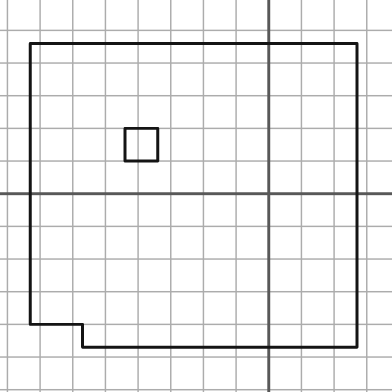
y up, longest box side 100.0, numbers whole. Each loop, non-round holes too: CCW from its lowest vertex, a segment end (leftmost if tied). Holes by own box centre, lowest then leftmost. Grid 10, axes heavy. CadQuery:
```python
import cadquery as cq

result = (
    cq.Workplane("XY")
    .moveTo(-57.0, -47.0)
    .lineTo(27.0, -47.0)
    .lineTo(27.0, 46.0)
    .lineTo(-73.0, 46.0)
    .lineTo(-73.0, -40.0)
    .lineTo(-57.0, -40.0)
    .close()
    .moveTo(-44.0, 10.0)
    .lineTo(-34.0, 10.0)
    .lineTo(-34.0, 20.0)
    .lineTo(-44.0, 20.0)
    .close()
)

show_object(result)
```